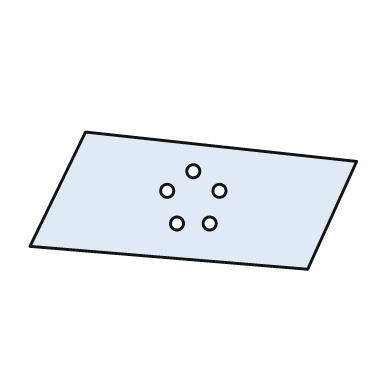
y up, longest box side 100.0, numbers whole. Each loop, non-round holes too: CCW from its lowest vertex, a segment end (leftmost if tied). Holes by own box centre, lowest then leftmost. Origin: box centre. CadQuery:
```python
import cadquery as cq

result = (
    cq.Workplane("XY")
    .moveTo(35.0, -21.0)
    .lineTo(50.0, 12.0)
    .lineTo(-33.0, 21.0)
    .lineTo(-50.0, -14.0)
    .close()
    .moveTo(-5.0, -7.0)
    .circle(2.0)
    .moveTo(5.0, -7.0)
    .circle(2.0)
    .moveTo(-8.0, 3.0)
    .circle(2.0)
    .moveTo(8.0, 3.0)
    .circle(2.0)
    .moveTo(0.0, 9.0)
    .circle(2.0)
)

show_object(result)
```